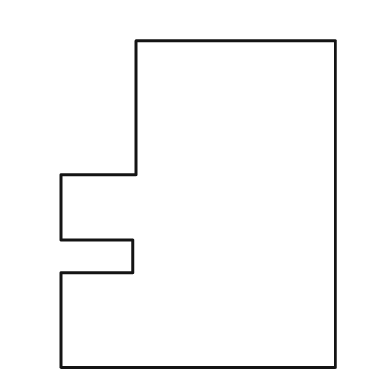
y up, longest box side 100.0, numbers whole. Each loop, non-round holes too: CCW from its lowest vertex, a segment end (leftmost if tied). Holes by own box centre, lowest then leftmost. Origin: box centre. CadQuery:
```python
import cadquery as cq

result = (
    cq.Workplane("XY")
    .moveTo(-42.0, -50.0)
    .lineTo(42.0, -50.0)
    .lineTo(42.0, 50.0)
    .lineTo(-19.0, 50.0)
    .lineTo(-19.0, 9.0)
    .lineTo(-42.0, 9.0)
    .lineTo(-42.0, -11.0)
    .lineTo(-20.0, -11.0)
    .lineTo(-20.0, -21.0)
    .lineTo(-42.0, -21.0)
    .close()
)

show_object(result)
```